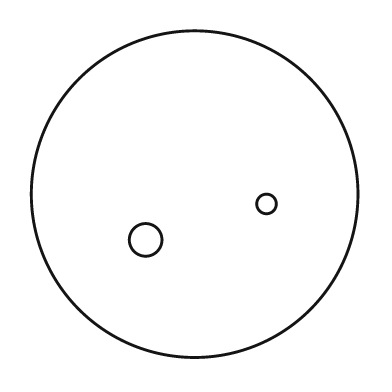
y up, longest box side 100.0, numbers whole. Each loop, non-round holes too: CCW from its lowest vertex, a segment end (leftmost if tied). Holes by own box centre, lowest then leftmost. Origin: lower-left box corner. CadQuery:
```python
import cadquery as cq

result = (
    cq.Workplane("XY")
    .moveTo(50.0, 50.0)
    .circle(50.0)
    .moveTo(35.0, 36.0)
    .circle(5.0)
    .moveTo(72.0, 47.0)
    .circle(3.0)
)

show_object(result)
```